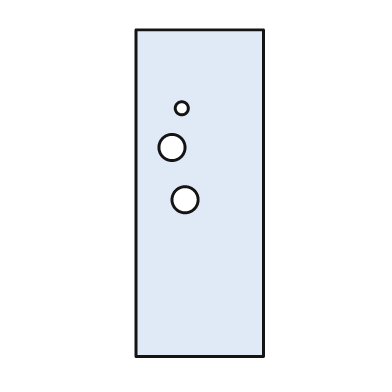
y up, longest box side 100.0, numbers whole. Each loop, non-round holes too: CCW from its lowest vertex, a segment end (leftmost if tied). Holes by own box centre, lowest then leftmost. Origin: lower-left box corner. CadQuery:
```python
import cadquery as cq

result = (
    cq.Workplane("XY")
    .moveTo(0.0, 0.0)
    .lineTo(39.0, 0.0)
    .lineTo(39.0, 100.0)
    .lineTo(0.0, 100.0)
    .close()
    .moveTo(15.0, 48.0)
    .circle(4.0)
    .moveTo(11.0, 64.0)
    .circle(4.0)
    .moveTo(14.0, 76.0)
    .circle(2.0)
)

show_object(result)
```